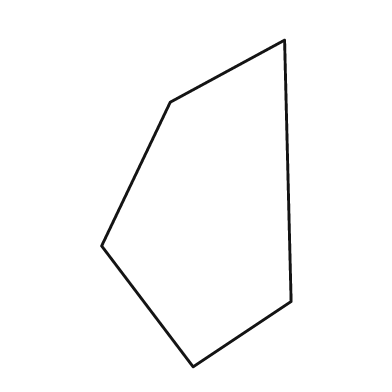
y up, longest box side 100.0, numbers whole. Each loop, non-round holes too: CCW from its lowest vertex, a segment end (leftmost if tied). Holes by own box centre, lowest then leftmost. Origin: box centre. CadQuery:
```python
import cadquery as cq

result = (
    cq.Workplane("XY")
    .moveTo(-1.0, -50.0)
    .lineTo(29.0, -30.0)
    .lineTo(27.0, 50.0)
    .lineTo(-8.0, 31.0)
    .lineTo(-29.0, -13.0)
    .close()
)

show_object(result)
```